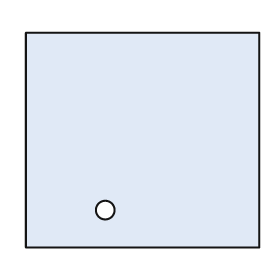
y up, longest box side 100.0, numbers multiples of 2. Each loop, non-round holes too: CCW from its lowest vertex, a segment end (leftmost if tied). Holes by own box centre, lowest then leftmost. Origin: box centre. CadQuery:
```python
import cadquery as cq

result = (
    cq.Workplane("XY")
    .moveTo(-50.0, -46.0)
    .lineTo(50.0, -46.0)
    .lineTo(50.0, 46.0)
    .lineTo(-50.0, 46.0)
    .close()
    .moveTo(-16.0, -30.0)
    .circle(4.0)
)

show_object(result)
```